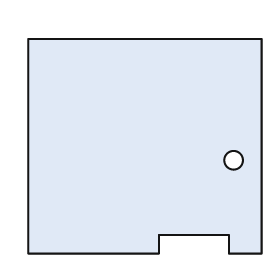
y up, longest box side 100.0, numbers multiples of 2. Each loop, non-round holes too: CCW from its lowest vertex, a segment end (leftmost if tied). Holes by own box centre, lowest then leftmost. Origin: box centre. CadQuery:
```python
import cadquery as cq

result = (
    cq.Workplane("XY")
    .moveTo(-50.0, -46.0)
    .lineTo(6.0, -46.0)
    .lineTo(6.0, -38.0)
    .lineTo(36.0, -38.0)
    .lineTo(36.0, -46.0)
    .lineTo(50.0, -46.0)
    .lineTo(50.0, 46.0)
    .lineTo(-50.0, 46.0)
    .close()
    .moveTo(38.0, -6.0)
    .circle(4.0)
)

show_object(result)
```